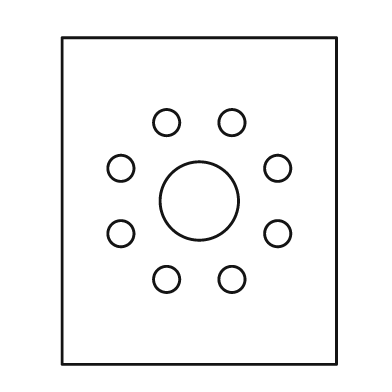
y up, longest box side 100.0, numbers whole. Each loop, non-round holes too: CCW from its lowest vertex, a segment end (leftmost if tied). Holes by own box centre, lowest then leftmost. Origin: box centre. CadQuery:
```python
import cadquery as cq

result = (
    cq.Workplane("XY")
    .moveTo(-42.0, -50.0)
    .lineTo(42.0, -50.0)
    .lineTo(42.0, 50.0)
    .lineTo(-42.0, 50.0)
    .close()
    .moveTo(-10.0, -24.0)
    .circle(4.0)
    .moveTo(10.0, -24.0)
    .circle(4.0)
    .moveTo(-24.0, -10.0)
    .circle(4.0)
    .moveTo(24.0, -10.0)
    .circle(4.0)
    .moveTo(0.0, 0.0)
    .circle(12.0)
    .moveTo(-24.0, 10.0)
    .circle(4.0)
    .moveTo(24.0, 10.0)
    .circle(4.0)
    .moveTo(-10.0, 24.0)
    .circle(4.0)
    .moveTo(10.0, 24.0)
    .circle(4.0)
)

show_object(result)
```